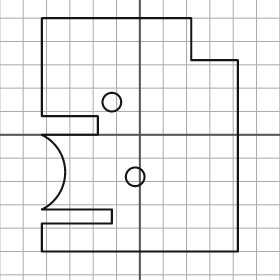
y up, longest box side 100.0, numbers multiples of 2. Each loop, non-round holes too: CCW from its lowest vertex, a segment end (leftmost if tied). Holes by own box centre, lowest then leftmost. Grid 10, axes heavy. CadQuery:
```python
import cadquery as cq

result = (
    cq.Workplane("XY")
    .moveTo(-42.0, -50.0)
    .lineTo(42.0, -50.0)
    .lineTo(42.0, 32.0)
    .lineTo(22.0, 32.0)
    .lineTo(22.0, 50.0)
    .lineTo(-42.0, 50.0)
    .lineTo(-42.0, 8.0)
    .lineTo(-18.0, 8.0)
    .lineTo(-18.0, 0.0)
    .lineTo(-42.0, 0.0)
    .threePointArc((-32.0, -16.0), (-42.0, -32.0))
    .lineTo(-12.0, -32.0)
    .lineTo(-12.0, -38.0)
    .lineTo(-42.0, -38.0)
    .close()
    .moveTo(-2.0, -18.0)
    .circle(4.0)
    .moveTo(-12.0, 14.0)
    .circle(4.0)
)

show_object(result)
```